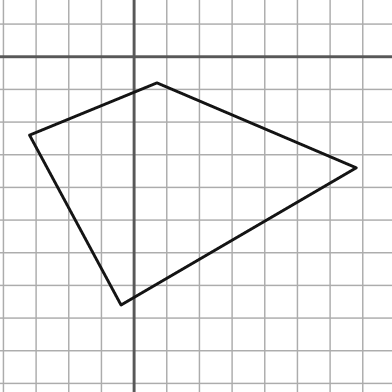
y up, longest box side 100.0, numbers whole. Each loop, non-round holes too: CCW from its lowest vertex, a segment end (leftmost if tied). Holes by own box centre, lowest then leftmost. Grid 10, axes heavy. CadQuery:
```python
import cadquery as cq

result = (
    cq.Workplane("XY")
    .moveTo(-4.0, -76.0)
    .lineTo(68.0, -34.0)
    .lineTo(7.0, -8.0)
    .lineTo(-32.0, -24.0)
    .close()
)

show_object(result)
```